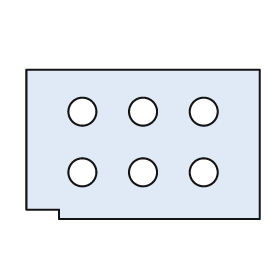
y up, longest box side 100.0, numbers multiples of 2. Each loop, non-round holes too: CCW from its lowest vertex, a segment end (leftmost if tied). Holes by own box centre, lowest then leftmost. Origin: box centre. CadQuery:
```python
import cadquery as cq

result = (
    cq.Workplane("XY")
    .moveTo(-36.0, -32.0)
    .lineTo(50.0, -32.0)
    .lineTo(50.0, 32.0)
    .lineTo(-50.0, 32.0)
    .lineTo(-50.0, -28.0)
    .lineTo(-36.0, -28.0)
    .close()
    .moveTo(-26.0, -12.0)
    .circle(6.0)
    .moveTo(0.0, -12.0)
    .circle(6.0)
    .moveTo(26.0, -12.0)
    .circle(6.0)
    .moveTo(-26.0, 14.0)
    .circle(6.0)
    .moveTo(0.0, 14.0)
    .circle(6.0)
    .moveTo(26.0, 14.0)
    .circle(6.0)
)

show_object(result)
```